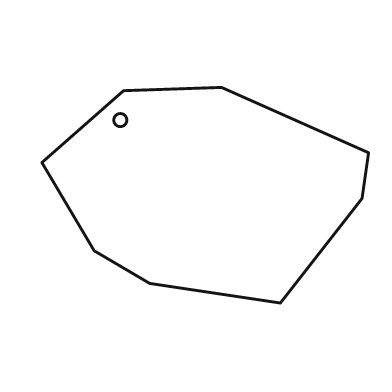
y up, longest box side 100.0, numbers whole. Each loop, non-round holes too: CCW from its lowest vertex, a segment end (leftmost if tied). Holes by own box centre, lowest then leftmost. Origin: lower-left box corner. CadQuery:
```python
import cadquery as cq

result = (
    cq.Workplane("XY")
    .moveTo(73.0, 0.0)
    .lineTo(98.0, 32.0)
    .lineTo(100.0, 46.0)
    .lineTo(55.0, 66.0)
    .lineTo(25.0, 65.0)
    .lineTo(0.0, 43.0)
    .lineTo(16.0, 16.0)
    .lineTo(33.0, 6.0)
    .close()
    .moveTo(24.0, 56.0)
    .circle(2.0)
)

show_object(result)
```